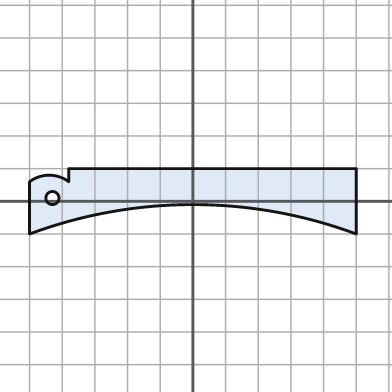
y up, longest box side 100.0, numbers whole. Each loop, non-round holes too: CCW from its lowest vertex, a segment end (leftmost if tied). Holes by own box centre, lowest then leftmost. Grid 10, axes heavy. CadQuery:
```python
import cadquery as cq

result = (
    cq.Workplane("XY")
    .moveTo(-50.0, -10.0)
    .threePointArc((0.0, -1.0), (50.0, -10.0))
    .lineTo(50.0, 10.0)
    .lineTo(-38.0, 10.0)
    .lineTo(-38.0, 6.0)
    .threePointArc((-44.0, 8.0), (-50.0, 6.0))
    .close()
    .moveTo(-43.0, 1.0)
    .circle(2.0)
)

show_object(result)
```